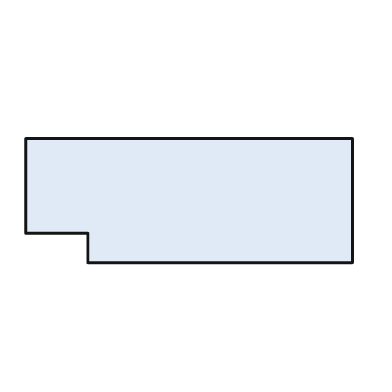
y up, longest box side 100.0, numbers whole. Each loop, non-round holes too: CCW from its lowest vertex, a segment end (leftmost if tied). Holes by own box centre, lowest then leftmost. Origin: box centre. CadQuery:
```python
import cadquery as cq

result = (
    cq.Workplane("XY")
    .moveTo(-31.0, -19.0)
    .lineTo(50.0, -19.0)
    .lineTo(50.0, 19.0)
    .lineTo(-50.0, 19.0)
    .lineTo(-50.0, -10.0)
    .lineTo(-31.0, -10.0)
    .close()
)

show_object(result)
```